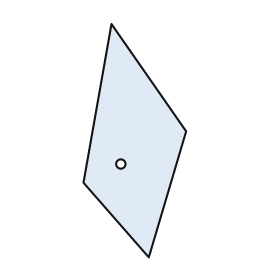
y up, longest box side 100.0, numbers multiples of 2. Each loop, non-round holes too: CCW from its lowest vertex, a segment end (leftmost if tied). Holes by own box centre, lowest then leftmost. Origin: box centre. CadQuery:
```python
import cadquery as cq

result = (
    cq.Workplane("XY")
    .moveTo(6.0, -50.0)
    .lineTo(22.0, 4.0)
    .lineTo(-10.0, 50.0)
    .lineTo(-22.0, -18.0)
    .close()
    .moveTo(-6.0, -10.0)
    .circle(2.0)
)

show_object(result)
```